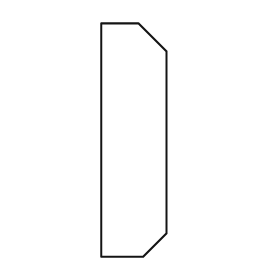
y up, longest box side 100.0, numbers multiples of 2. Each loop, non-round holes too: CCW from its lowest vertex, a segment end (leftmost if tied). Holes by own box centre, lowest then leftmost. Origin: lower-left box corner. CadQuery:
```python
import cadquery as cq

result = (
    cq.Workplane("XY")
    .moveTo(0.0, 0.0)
    .lineTo(18.0, 0.0)
    .lineTo(28.0, 10.0)
    .lineTo(28.0, 88.0)
    .lineTo(16.0, 100.0)
    .lineTo(0.0, 100.0)
    .close()
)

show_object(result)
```